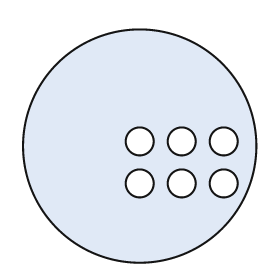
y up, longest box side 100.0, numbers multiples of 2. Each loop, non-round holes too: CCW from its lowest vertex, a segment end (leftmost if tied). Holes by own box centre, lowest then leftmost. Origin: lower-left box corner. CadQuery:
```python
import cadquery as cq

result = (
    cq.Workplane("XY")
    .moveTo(50.0, 50.0)
    .circle(50.0)
    .moveTo(50.0, 34.0)
    .circle(6.0)
    .moveTo(68.0, 34.0)
    .circle(6.0)
    .moveTo(86.0, 34.0)
    .circle(6.0)
    .moveTo(50.0, 52.0)
    .circle(6.0)
    .moveTo(68.0, 52.0)
    .circle(6.0)
    .moveTo(86.0, 52.0)
    .circle(6.0)
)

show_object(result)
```